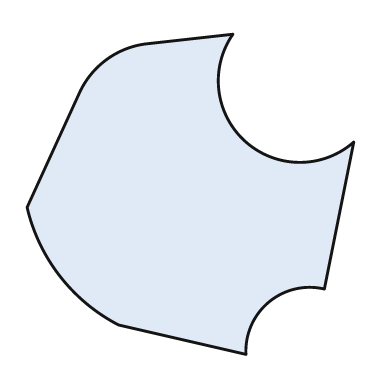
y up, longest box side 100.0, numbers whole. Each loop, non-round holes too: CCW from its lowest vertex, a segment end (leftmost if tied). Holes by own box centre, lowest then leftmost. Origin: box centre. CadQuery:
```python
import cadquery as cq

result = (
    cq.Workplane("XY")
    .moveTo(17.0, -49.0)
    .threePointArc((24.0, -33.0), (41.0, -29.0))
    .lineTo(50.0, 16.0)
    .threePointArc((17.0, 16.0), (13.0, 49.0))
    .lineTo(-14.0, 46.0)
    .threePointArc((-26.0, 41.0), (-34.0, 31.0))
    .lineTo(-50.0, -4.0)
    .threePointArc((-40.0, -25.0), (-22.0, -40.0))
    .close()
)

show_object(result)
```